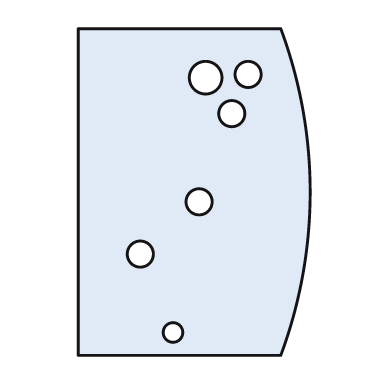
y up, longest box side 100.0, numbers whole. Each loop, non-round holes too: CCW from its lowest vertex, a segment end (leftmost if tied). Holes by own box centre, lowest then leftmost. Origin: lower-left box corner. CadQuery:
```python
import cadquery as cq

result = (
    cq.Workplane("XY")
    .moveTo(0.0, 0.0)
    .lineTo(62.0, 0.0)
    .threePointArc((71.0, 50.0), (62.0, 100.0))
    .lineTo(0.0, 100.0)
    .close()
    .moveTo(29.0, 7.0)
    .circle(3.0)
    .moveTo(19.0, 31.0)
    .circle(4.0)
    .moveTo(37.0, 47.0)
    .circle(4.0)
    .moveTo(47.0, 74.0)
    .circle(4.0)
    .moveTo(39.0, 85.0)
    .circle(5.0)
    .moveTo(52.0, 86.0)
    .circle(4.0)
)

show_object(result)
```